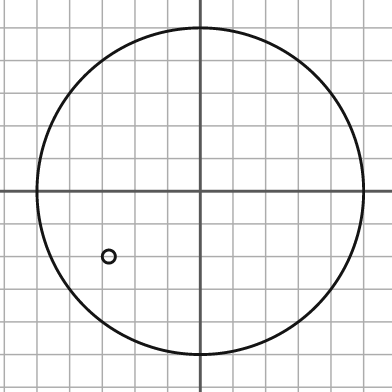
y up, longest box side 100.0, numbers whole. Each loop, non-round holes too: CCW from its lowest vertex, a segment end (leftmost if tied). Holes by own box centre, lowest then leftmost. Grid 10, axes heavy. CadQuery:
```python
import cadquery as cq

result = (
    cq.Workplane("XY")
    .moveTo(0.0, 0.0)
    .circle(50.0)
    .moveTo(-28.0, -20.0)
    .circle(2.0)
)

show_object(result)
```